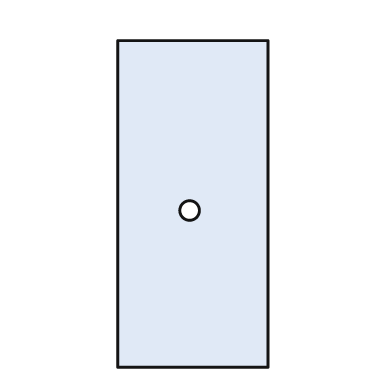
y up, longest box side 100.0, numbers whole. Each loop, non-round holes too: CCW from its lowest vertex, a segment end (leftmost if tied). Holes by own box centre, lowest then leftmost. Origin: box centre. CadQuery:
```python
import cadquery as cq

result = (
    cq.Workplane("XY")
    .moveTo(-23.0, -50.0)
    .lineTo(23.0, -50.0)
    .lineTo(23.0, 50.0)
    .lineTo(-23.0, 50.0)
    .close()
    .moveTo(-1.0, -2.0)
    .circle(3.0)
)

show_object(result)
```